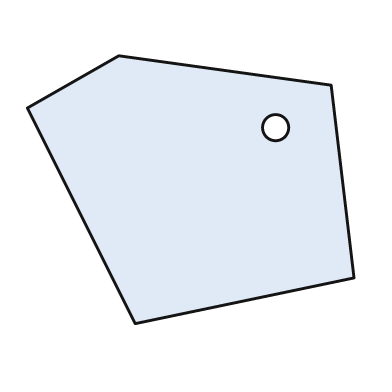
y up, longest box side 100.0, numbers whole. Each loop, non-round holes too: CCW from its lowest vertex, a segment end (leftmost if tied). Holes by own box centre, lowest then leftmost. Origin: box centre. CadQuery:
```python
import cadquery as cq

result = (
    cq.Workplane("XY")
    .moveTo(-17.0, -41.0)
    .lineTo(50.0, -27.0)
    .lineTo(43.0, 32.0)
    .lineTo(-22.0, 41.0)
    .lineTo(-50.0, 25.0)
    .close()
    .moveTo(26.0, 19.0)
    .circle(4.0)
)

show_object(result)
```